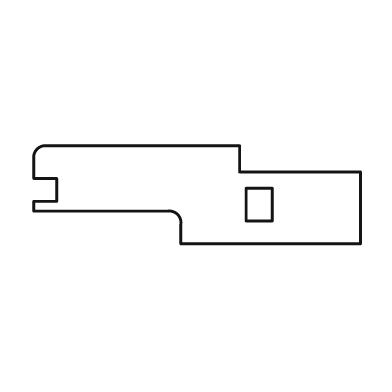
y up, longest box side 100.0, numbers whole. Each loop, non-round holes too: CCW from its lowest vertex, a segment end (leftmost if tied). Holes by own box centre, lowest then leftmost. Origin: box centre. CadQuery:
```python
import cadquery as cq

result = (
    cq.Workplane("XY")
    .moveTo(-5.0, -15.0)
    .lineTo(50.0, -15.0)
    .lineTo(50.0, 7.0)
    .lineTo(13.0, 7.0)
    .lineTo(13.0, 15.0)
    .lineTo(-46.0, 15.0)
    .threePointArc((-49.0, 14.0), (-50.0, 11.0))
    .lineTo(-50.0, 5.0)
    .lineTo(-43.0, 5.0)
    .lineTo(-43.0, -2.0)
    .lineTo(-50.0, -2.0)
    .lineTo(-50.0, -5.0)
    .lineTo(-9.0, -5.0)
    .threePointArc((-6.0, -6.0), (-5.0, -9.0))
    .close()
    .moveTo(15.0, -8.0)
    .lineTo(23.0, -8.0)
    .lineTo(23.0, 2.0)
    .lineTo(15.0, 2.0)
    .close()
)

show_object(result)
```